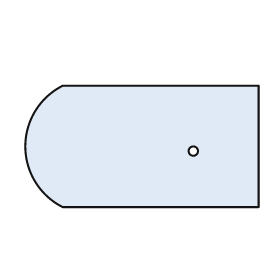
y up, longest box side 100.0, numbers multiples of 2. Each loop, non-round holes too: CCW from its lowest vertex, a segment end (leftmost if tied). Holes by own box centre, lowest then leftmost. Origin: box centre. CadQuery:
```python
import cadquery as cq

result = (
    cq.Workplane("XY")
    .moveTo(-34.0, -26.0)
    .lineTo(50.0, -26.0)
    .lineTo(50.0, 26.0)
    .lineTo(-34.0, 26.0)
    .threePointArc((-50.0, 0.0), (-34.0, -26.0))
    .close()
    .moveTo(22.0, -2.0)
    .circle(2.0)
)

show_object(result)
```